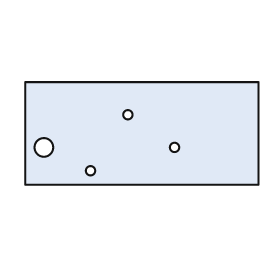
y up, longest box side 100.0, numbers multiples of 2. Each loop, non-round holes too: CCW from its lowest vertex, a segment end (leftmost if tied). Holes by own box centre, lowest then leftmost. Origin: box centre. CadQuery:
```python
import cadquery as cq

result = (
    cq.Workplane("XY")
    .moveTo(-50.0, -22.0)
    .lineTo(50.0, -22.0)
    .lineTo(50.0, 22.0)
    .lineTo(-50.0, 22.0)
    .close()
    .moveTo(-22.0, -16.0)
    .circle(2.0)
    .moveTo(-42.0, -6.0)
    .circle(4.0)
    .moveTo(14.0, -6.0)
    .circle(2.0)
    .moveTo(-6.0, 8.0)
    .circle(2.0)
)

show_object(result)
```